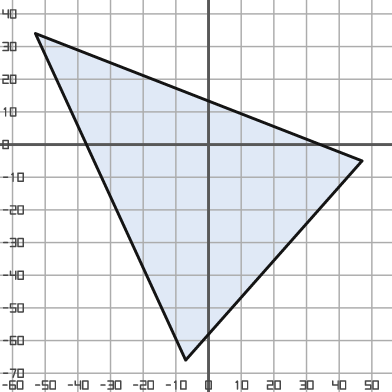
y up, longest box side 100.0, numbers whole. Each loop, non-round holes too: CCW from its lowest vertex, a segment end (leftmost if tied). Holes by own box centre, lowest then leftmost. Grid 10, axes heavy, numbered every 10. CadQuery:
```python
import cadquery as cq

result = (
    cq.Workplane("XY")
    .moveTo(-7.0, -66.0)
    .lineTo(47.0, -5.0)
    .lineTo(-53.0, 34.0)
    .close()
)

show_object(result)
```